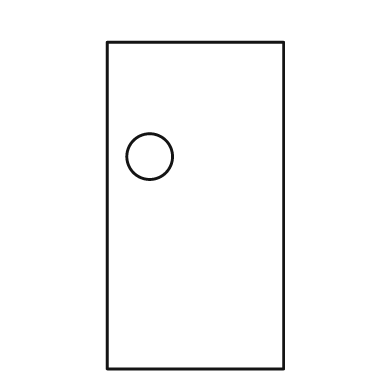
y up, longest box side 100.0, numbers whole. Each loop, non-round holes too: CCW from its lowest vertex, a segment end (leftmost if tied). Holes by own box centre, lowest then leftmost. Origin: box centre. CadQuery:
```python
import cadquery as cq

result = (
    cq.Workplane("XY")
    .moveTo(-27.0, -50.0)
    .lineTo(27.0, -50.0)
    .lineTo(27.0, 50.0)
    .lineTo(-27.0, 50.0)
    .close()
    .moveTo(-14.0, 15.0)
    .circle(7.0)
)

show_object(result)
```